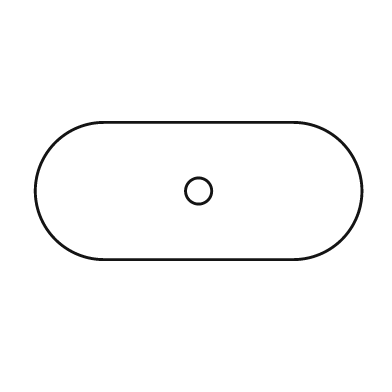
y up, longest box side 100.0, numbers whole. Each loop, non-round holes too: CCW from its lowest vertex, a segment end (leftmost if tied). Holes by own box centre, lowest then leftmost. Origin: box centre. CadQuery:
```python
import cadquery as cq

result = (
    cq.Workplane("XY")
    .moveTo(-29.0, -21.0)
    .lineTo(29.0, -21.0)
    .threePointArc((50.0, 0.0), (29.0, 21.0))
    .lineTo(-29.0, 21.0)
    .threePointArc((-50.0, 0.0), (-29.0, -21.0))
    .close()
    .moveTo(0.0, 0.0)
    .circle(4.0)
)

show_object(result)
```